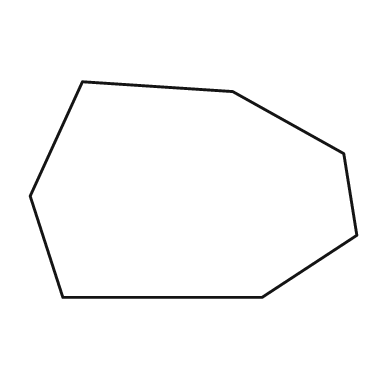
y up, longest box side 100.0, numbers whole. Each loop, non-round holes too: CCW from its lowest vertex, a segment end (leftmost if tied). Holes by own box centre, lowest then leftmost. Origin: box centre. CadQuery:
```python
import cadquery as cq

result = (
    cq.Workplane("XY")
    .moveTo(-40.0, -33.0)
    .lineTo(21.0, -33.0)
    .lineTo(50.0, -14.0)
    .lineTo(46.0, 11.0)
    .lineTo(12.0, 30.0)
    .lineTo(-34.0, 33.0)
    .lineTo(-50.0, -2.0)
    .close()
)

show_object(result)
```